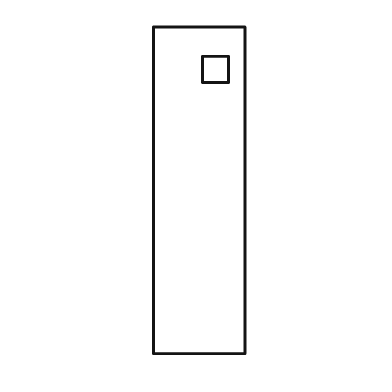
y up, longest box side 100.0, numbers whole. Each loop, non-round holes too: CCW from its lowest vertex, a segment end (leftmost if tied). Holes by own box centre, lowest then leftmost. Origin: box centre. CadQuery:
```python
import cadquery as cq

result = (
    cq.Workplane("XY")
    .moveTo(-14.0, -50.0)
    .lineTo(14.0, -50.0)
    .lineTo(14.0, 50.0)
    .lineTo(-14.0, 50.0)
    .close()
    .moveTo(1.0, 33.0)
    .lineTo(9.0, 33.0)
    .lineTo(9.0, 41.0)
    .lineTo(1.0, 41.0)
    .close()
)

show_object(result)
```